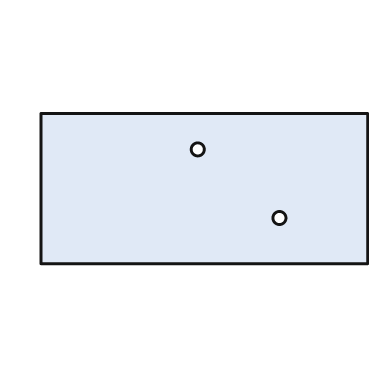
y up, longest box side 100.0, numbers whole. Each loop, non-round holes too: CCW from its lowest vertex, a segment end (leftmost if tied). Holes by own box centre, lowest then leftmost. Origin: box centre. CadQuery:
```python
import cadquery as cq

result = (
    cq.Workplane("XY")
    .moveTo(-50.0, -23.0)
    .lineTo(50.0, -23.0)
    .lineTo(50.0, 23.0)
    .lineTo(-50.0, 23.0)
    .close()
    .moveTo(23.0, -9.0)
    .circle(2.0)
    .moveTo(-2.0, 12.0)
    .circle(2.0)
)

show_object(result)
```